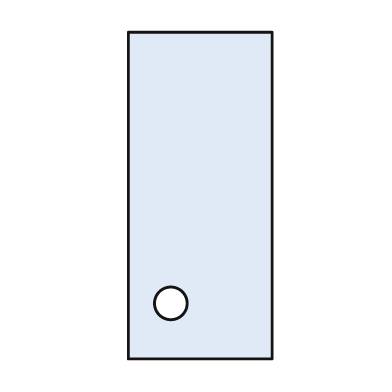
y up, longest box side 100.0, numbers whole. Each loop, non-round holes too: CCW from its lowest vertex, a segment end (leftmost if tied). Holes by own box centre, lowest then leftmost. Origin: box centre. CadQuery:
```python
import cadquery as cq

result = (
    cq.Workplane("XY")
    .moveTo(-22.0, -50.0)
    .lineTo(22.0, -50.0)
    .lineTo(22.0, 50.0)
    .lineTo(-22.0, 50.0)
    .close()
    .moveTo(-9.0, -33.0)
    .circle(5.0)
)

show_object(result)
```